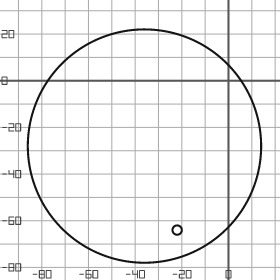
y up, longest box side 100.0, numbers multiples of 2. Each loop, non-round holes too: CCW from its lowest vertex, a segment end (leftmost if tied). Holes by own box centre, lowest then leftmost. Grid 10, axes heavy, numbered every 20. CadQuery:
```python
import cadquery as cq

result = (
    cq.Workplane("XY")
    .moveTo(-36.0, -28.0)
    .circle(50.0)
    .moveTo(-22.0, -64.0)
    .circle(2.0)
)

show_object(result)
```